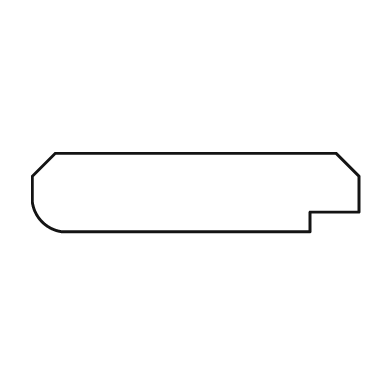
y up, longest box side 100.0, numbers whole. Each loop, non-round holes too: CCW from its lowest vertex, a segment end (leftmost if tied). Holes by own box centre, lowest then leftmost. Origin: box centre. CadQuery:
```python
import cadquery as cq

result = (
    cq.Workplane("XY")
    .moveTo(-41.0, -12.0)
    .lineTo(35.0, -12.0)
    .lineTo(35.0, -6.0)
    .lineTo(50.0, -6.0)
    .lineTo(50.0, 5.0)
    .lineTo(43.0, 12.0)
    .lineTo(-43.0, 12.0)
    .lineTo(-50.0, 5.0)
    .lineTo(-50.0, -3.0)
    .threePointArc((-47.0, -9.0), (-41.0, -12.0))
    .close()
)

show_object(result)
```